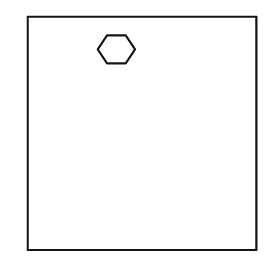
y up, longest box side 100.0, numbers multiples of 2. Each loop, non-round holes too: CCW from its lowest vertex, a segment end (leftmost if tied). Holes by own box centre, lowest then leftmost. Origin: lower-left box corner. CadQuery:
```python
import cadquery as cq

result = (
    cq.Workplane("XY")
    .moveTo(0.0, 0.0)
    .lineTo(98.0, 0.0)
    .lineTo(98.0, 100.0)
    .lineTo(0.0, 100.0)
    .close()
    .moveTo(34.0, 80.0)
    .lineTo(42.0, 80.0)
    .lineTo(46.0, 86.0)
    .lineTo(42.0, 92.0)
    .lineTo(34.0, 92.0)
    .lineTo(30.0, 86.0)
    .close()
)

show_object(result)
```